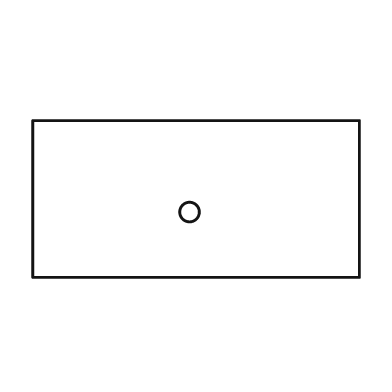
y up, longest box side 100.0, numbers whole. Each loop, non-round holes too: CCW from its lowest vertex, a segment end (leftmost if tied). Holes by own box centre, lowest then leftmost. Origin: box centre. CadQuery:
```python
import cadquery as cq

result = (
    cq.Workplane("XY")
    .moveTo(-50.0, -24.0)
    .lineTo(50.0, -24.0)
    .lineTo(50.0, 24.0)
    .lineTo(-50.0, 24.0)
    .close()
    .moveTo(-2.0, -4.0)
    .circle(3.0)
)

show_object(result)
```